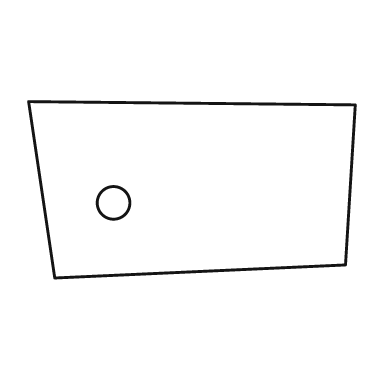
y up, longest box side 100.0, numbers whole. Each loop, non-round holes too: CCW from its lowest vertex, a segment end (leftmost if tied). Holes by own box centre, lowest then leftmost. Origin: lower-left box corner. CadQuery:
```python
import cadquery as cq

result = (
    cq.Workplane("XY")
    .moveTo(8.0, 0.0)
    .lineTo(97.0, 4.0)
    .lineTo(100.0, 53.0)
    .lineTo(0.0, 54.0)
    .close()
    .moveTo(26.0, 23.0)
    .circle(5.0)
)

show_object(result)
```